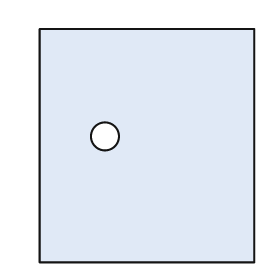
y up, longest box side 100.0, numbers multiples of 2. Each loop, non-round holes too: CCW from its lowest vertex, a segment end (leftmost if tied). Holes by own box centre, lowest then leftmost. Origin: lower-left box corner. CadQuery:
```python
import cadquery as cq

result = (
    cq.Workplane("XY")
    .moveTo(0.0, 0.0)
    .lineTo(92.0, 0.0)
    .lineTo(92.0, 100.0)
    .lineTo(0.0, 100.0)
    .close()
    .moveTo(28.0, 54.0)
    .circle(6.0)
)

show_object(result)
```